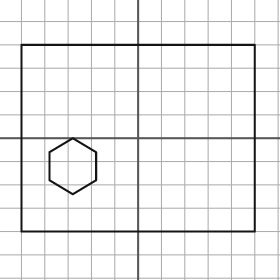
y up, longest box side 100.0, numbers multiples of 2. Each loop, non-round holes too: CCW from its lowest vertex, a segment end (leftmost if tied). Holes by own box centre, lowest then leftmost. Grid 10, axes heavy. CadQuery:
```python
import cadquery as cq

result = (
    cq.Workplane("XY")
    .moveTo(-50.0, -40.0)
    .lineTo(50.0, -40.0)
    .lineTo(50.0, 40.0)
    .lineTo(-50.0, 40.0)
    .close()
    .moveTo(-28.0, -24.0)
    .lineTo(-18.0, -18.0)
    .lineTo(-18.0, -6.0)
    .lineTo(-28.0, 0.0)
    .lineTo(-38.0, -6.0)
    .lineTo(-38.0, -18.0)
    .close()
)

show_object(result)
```